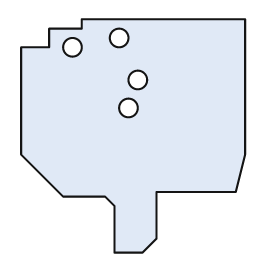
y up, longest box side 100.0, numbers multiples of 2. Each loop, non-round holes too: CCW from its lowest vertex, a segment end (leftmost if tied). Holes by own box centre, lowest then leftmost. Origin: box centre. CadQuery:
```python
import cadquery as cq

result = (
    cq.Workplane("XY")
    .moveTo(-8.0, -50.0)
    .lineTo(4.0, -50.0)
    .lineTo(10.0, -44.0)
    .lineTo(10.0, -24.0)
    .lineTo(44.0, -24.0)
    .lineTo(48.0, -8.0)
    .lineTo(48.0, 50.0)
    .lineTo(-22.0, 50.0)
    .lineTo(-22.0, 46.0)
    .lineTo(-36.0, 46.0)
    .lineTo(-36.0, 38.0)
    .lineTo(-48.0, 38.0)
    .lineTo(-48.0, -8.0)
    .lineTo(-30.0, -26.0)
    .lineTo(-12.0, -26.0)
    .lineTo(-8.0, -30.0)
    .close()
    .moveTo(-2.0, 12.0)
    .circle(4.0)
    .moveTo(2.0, 24.0)
    .circle(4.0)
    .moveTo(-26.0, 38.0)
    .circle(4.0)
    .moveTo(-6.0, 42.0)
    .circle(4.0)
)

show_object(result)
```